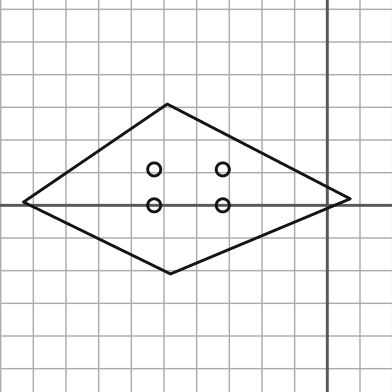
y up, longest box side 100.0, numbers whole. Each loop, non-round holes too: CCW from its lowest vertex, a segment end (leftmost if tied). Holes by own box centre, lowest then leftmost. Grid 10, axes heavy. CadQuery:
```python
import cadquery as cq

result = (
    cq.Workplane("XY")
    .moveTo(-48.0, -21.0)
    .lineTo(7.0, 2.0)
    .lineTo(-49.0, 31.0)
    .lineTo(-93.0, 1.0)
    .close()
    .moveTo(-53.0, 0.0)
    .circle(2.0)
    .moveTo(-32.0, 0.0)
    .circle(2.0)
    .moveTo(-53.0, 11.0)
    .circle(2.0)
    .moveTo(-32.0, 11.0)
    .circle(2.0)
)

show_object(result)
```